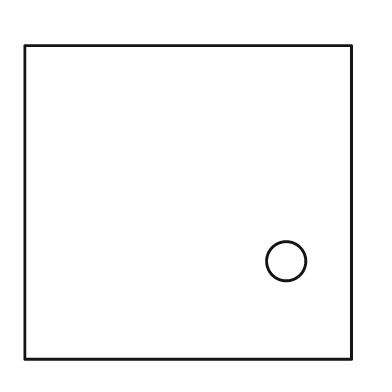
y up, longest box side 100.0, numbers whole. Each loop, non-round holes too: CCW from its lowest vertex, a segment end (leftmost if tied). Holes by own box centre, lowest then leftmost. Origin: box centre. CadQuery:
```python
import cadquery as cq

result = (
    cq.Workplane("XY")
    .moveTo(-50.0, -48.0)
    .lineTo(50.0, -48.0)
    .lineTo(50.0, 48.0)
    .lineTo(-50.0, 48.0)
    .close()
    .moveTo(30.0, -18.0)
    .circle(6.0)
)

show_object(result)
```